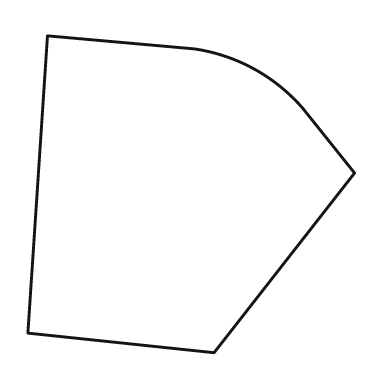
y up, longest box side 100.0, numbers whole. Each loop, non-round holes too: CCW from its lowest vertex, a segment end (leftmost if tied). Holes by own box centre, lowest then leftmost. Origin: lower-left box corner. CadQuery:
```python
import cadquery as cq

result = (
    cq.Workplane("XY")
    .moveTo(57.0, 0.0)
    .lineTo(100.0, 55.0)
    .lineTo(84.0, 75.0)
    .threePointArc((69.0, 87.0), (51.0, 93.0))
    .lineTo(6.0, 97.0)
    .lineTo(0.0, 6.0)
    .close()
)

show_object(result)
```